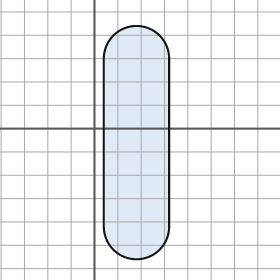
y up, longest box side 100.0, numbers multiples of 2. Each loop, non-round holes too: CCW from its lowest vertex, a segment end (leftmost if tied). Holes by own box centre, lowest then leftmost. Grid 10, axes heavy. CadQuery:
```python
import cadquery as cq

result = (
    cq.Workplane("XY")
    .moveTo(4.0, -42.0)
    .threePointArc((18.0, -56.0), (32.0, -42.0))
    .lineTo(32.0, 30.0)
    .threePointArc((18.0, 44.0), (4.0, 30.0))
    .close()
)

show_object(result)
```